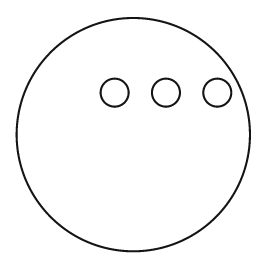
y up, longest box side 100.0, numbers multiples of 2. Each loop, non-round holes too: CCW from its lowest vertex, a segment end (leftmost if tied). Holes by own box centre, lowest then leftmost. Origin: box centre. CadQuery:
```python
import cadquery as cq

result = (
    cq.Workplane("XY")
    .moveTo(0.0, 0.0)
    .circle(50.0)
    .moveTo(-8.0, 18.0)
    .circle(6.0)
    .moveTo(14.0, 18.0)
    .circle(6.0)
    .moveTo(36.0, 18.0)
    .circle(6.0)
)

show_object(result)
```